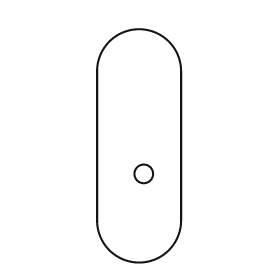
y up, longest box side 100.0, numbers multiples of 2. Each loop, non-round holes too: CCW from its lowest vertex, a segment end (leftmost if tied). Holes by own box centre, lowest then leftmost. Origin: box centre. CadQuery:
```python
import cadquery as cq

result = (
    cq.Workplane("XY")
    .moveTo(-18.0, -32.0)
    .threePointArc((0.0, -50.0), (18.0, -32.0))
    .lineTo(18.0, 32.0)
    .threePointArc((0.0, 50.0), (-18.0, 32.0))
    .close()
    .moveTo(2.0, -12.0)
    .circle(4.0)
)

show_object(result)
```